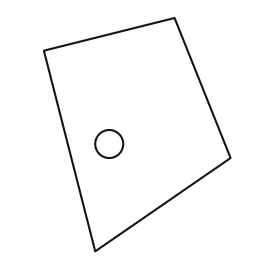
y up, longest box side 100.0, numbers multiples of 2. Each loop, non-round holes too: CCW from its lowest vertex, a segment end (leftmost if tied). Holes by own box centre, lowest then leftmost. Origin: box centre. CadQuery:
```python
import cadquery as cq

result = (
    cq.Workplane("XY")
    .moveTo(-18.0, -50.0)
    .lineTo(40.0, -10.0)
    .lineTo(16.0, 50.0)
    .lineTo(-40.0, 36.0)
    .close()
    .moveTo(-12.0, -4.0)
    .circle(6.0)
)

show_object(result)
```